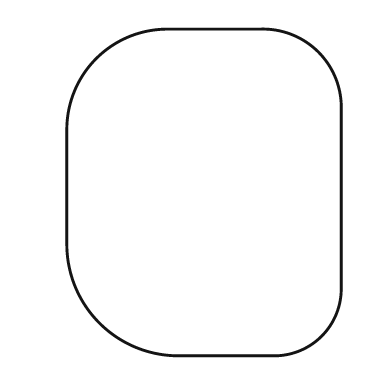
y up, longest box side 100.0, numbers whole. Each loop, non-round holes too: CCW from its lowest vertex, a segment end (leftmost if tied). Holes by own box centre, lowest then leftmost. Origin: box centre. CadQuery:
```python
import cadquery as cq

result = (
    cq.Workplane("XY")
    .moveTo(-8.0, -50.0)
    .lineTo(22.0, -50.0)
    .threePointArc((36.0, -44.0), (42.0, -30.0))
    .lineTo(42.0, 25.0)
    .threePointArc((35.0, 43.0), (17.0, 50.0))
    .lineTo(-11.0, 50.0)
    .threePointArc((-33.0, 41.0), (-42.0, 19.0))
    .lineTo(-42.0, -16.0)
    .threePointArc((-32.0, -40.0), (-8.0, -50.0))
    .close()
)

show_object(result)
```